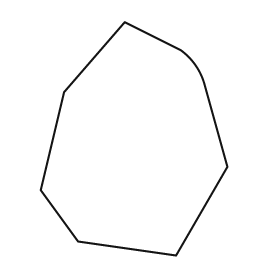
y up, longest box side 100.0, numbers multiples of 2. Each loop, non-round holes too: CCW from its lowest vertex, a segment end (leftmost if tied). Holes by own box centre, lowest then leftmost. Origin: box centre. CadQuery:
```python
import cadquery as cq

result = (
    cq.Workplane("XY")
    .moveTo(18.0, -50.0)
    .lineTo(40.0, -12.0)
    .lineTo(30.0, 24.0)
    .threePointArc((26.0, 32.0), (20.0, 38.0))
    .lineTo(-4.0, 50.0)
    .lineTo(-30.0, 20.0)
    .lineTo(-40.0, -22.0)
    .lineTo(-24.0, -44.0)
    .close()
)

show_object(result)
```